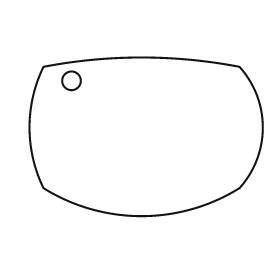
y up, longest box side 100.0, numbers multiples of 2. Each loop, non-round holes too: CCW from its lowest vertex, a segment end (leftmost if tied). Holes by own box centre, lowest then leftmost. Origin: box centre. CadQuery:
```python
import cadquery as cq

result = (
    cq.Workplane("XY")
    .moveTo(-44.0, -22.0)
    .threePointArc((-2.0, -34.0), (40.0, -22.0))
    .threePointArc((50.0, 4.0), (40.0, 30.0))
    .threePointArc((-2.0, 34.0), (-44.0, 30.0))
    .threePointArc((-50.0, 4.0), (-44.0, -22.0))
    .close()
    .moveTo(-32.0, 24.0)
    .circle(4.0)
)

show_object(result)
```